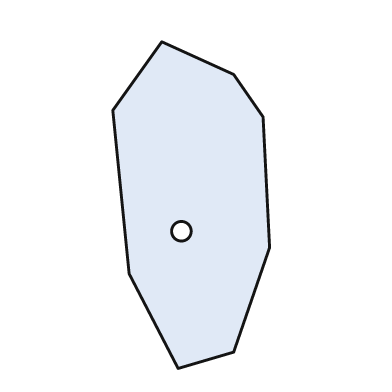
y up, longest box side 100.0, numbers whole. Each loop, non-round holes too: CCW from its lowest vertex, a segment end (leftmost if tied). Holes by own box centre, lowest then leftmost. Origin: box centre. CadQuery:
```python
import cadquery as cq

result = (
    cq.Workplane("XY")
    .moveTo(-4.0, -50.0)
    .lineTo(13.0, -45.0)
    .lineTo(24.0, -13.0)
    .lineTo(22.0, 27.0)
    .lineTo(13.0, 40.0)
    .lineTo(-9.0, 50.0)
    .lineTo(-24.0, 29.0)
    .lineTo(-19.0, -21.0)
    .close()
    .moveTo(-3.0, -8.0)
    .circle(3.0)
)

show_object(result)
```